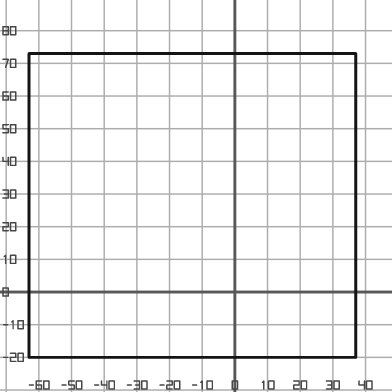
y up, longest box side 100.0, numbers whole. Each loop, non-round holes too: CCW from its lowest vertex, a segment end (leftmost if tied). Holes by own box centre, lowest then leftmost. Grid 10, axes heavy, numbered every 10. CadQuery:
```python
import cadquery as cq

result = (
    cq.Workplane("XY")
    .moveTo(-63.0, -20.0)
    .lineTo(37.0, -20.0)
    .lineTo(37.0, 73.0)
    .lineTo(-63.0, 73.0)
    .close()
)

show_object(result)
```